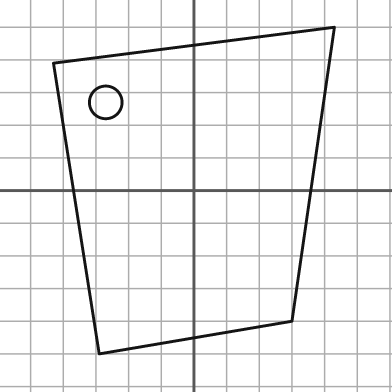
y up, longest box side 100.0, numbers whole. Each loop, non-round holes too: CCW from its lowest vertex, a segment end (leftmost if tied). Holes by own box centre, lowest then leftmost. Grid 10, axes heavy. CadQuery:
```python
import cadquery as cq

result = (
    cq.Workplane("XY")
    .moveTo(-29.0, -50.0)
    .lineTo(30.0, -40.0)
    .lineTo(43.0, 50.0)
    .lineTo(-43.0, 39.0)
    .close()
    .moveTo(-27.0, 27.0)
    .circle(5.0)
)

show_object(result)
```